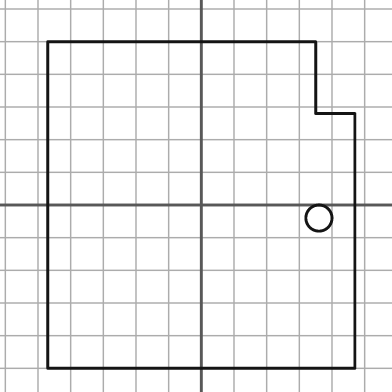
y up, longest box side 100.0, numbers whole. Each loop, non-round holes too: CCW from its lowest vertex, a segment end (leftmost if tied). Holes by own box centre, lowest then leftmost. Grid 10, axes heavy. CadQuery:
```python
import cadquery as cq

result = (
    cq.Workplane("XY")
    .moveTo(-47.0, -50.0)
    .lineTo(47.0, -50.0)
    .lineTo(47.0, 28.0)
    .lineTo(35.0, 28.0)
    .lineTo(35.0, 50.0)
    .lineTo(-47.0, 50.0)
    .close()
    .moveTo(36.0, -4.0)
    .circle(4.0)
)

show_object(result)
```